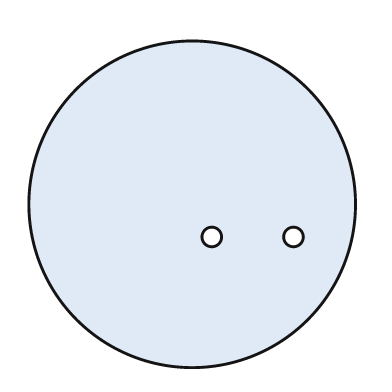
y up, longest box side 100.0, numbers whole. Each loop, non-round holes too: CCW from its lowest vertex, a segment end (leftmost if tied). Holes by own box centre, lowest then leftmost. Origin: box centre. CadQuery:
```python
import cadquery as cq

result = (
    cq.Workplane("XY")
    .moveTo(0.0, 0.0)
    .circle(50.0)
    .moveTo(6.0, -10.0)
    .circle(3.0)
    .moveTo(31.0, -10.0)
    .circle(3.0)
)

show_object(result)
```